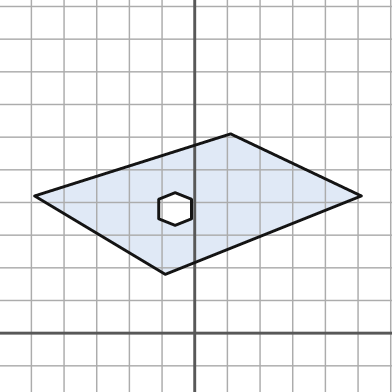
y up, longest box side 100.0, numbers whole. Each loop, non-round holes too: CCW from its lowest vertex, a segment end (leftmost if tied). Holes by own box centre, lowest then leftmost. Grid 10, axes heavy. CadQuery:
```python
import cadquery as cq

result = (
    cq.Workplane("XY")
    .moveTo(-9.0, 18.0)
    .lineTo(51.0, 42.0)
    .lineTo(11.0, 61.0)
    .lineTo(-49.0, 42.0)
    .close()
    .moveTo(-6.0, 33.0)
    .lineTo(-1.0, 35.0)
    .lineTo(-1.0, 41.0)
    .lineTo(-6.0, 43.0)
    .lineTo(-11.0, 41.0)
    .lineTo(-11.0, 35.0)
    .close()
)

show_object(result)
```